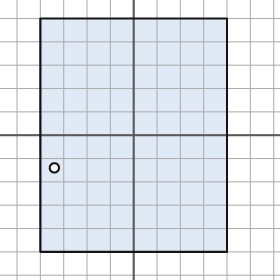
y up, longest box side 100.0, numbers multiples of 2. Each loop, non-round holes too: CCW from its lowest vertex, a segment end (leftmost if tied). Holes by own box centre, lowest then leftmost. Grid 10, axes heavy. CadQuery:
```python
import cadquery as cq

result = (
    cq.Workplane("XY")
    .moveTo(-40.0, -50.0)
    .lineTo(40.0, -50.0)
    .lineTo(40.0, 50.0)
    .lineTo(-40.0, 50.0)
    .close()
    .moveTo(-34.0, -14.0)
    .circle(2.0)
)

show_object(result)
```